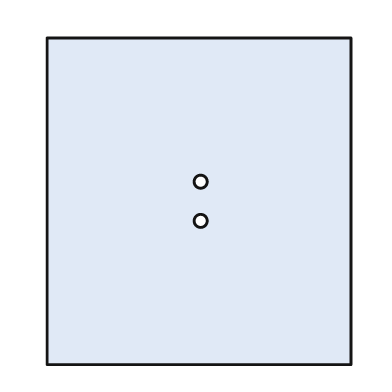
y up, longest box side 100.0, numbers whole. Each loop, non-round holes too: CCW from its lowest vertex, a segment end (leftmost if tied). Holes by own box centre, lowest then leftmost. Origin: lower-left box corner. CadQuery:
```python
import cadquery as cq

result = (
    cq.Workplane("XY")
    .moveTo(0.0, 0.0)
    .lineTo(93.0, 0.0)
    .lineTo(93.0, 100.0)
    .lineTo(0.0, 100.0)
    .close()
    .moveTo(47.0, 44.0)
    .circle(2.0)
    .moveTo(47.0, 56.0)
    .circle(2.0)
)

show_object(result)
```